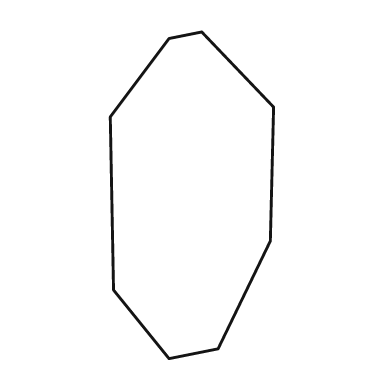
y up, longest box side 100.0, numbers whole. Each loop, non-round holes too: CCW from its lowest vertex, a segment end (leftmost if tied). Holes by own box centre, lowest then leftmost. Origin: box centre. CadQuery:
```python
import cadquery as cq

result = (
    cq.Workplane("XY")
    .moveTo(-7.0, -50.0)
    .lineTo(8.0, -47.0)
    .lineTo(24.0, -14.0)
    .lineTo(25.0, 27.0)
    .lineTo(3.0, 50.0)
    .lineTo(-7.0, 48.0)
    .lineTo(-25.0, 24.0)
    .lineTo(-24.0, -29.0)
    .close()
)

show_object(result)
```